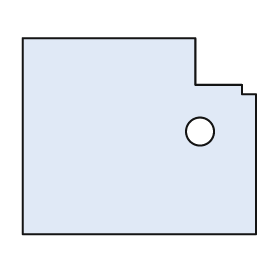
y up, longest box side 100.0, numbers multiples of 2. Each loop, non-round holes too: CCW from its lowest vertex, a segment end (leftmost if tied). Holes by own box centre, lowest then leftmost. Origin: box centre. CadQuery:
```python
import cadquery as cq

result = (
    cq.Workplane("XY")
    .moveTo(-50.0, -42.0)
    .lineTo(50.0, -42.0)
    .lineTo(50.0, 18.0)
    .lineTo(44.0, 18.0)
    .lineTo(44.0, 22.0)
    .lineTo(24.0, 22.0)
    .lineTo(24.0, 42.0)
    .lineTo(-50.0, 42.0)
    .close()
    .moveTo(26.0, 2.0)
    .circle(6.0)
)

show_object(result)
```